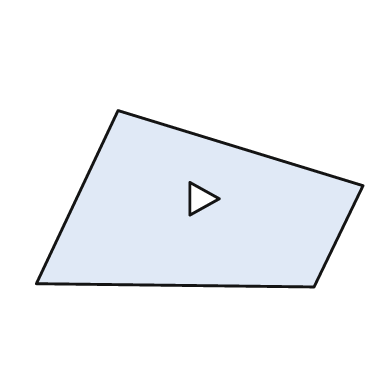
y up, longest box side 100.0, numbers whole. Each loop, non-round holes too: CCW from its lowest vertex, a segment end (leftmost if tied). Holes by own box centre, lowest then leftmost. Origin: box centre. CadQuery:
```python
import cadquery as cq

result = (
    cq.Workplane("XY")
    .moveTo(35.0, -27.0)
    .lineTo(50.0, 4.0)
    .lineTo(-25.0, 27.0)
    .lineTo(-50.0, -26.0)
    .close()
    .moveTo(-3.0, -5.0)
    .lineTo(6.0, 0.0)
    .lineTo(-3.0, 5.0)
    .close()
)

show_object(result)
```